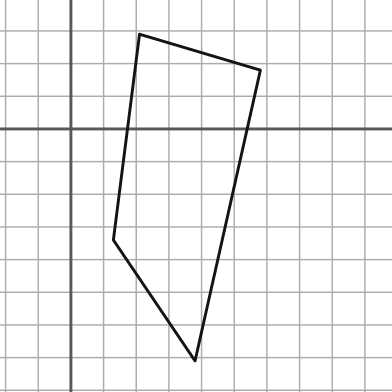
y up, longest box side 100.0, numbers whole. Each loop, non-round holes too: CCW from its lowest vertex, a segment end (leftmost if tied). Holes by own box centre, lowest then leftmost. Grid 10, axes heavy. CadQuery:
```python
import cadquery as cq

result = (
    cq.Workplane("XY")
    .moveTo(38.0, -71.0)
    .lineTo(58.0, 18.0)
    .lineTo(21.0, 29.0)
    .lineTo(13.0, -34.0)
    .close()
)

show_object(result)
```